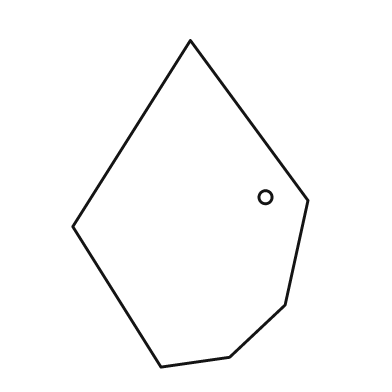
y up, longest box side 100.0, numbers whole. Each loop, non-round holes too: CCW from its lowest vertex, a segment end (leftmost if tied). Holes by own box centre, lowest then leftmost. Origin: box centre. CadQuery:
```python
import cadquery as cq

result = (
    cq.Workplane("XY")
    .moveTo(-9.0, -50.0)
    .lineTo(12.0, -47.0)
    .lineTo(29.0, -31.0)
    .lineTo(36.0, 1.0)
    .lineTo(0.0, 50.0)
    .lineTo(-36.0, -7.0)
    .close()
    .moveTo(23.0, 2.0)
    .circle(2.0)
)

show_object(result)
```